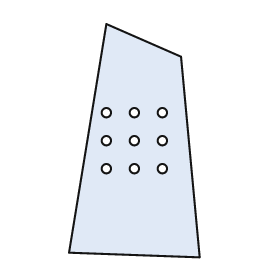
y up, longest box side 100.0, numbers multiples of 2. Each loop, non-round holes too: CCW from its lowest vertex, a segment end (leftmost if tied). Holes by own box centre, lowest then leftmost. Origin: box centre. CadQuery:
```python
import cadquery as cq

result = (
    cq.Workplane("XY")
    .moveTo(28.0, -50.0)
    .lineTo(20.0, 36.0)
    .lineTo(-12.0, 50.0)
    .lineTo(-28.0, -48.0)
    .close()
    .moveTo(-12.0, -12.0)
    .circle(2.0)
    .moveTo(0.0, -12.0)
    .circle(2.0)
    .moveTo(12.0, -12.0)
    .circle(2.0)
    .moveTo(-12.0, 0.0)
    .circle(2.0)
    .moveTo(0.0, 0.0)
    .circle(2.0)
    .moveTo(12.0, 0.0)
    .circle(2.0)
    .moveTo(-12.0, 12.0)
    .circle(2.0)
    .moveTo(0.0, 12.0)
    .circle(2.0)
    .moveTo(12.0, 12.0)
    .circle(2.0)
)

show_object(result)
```